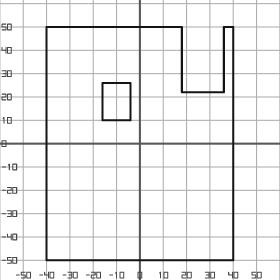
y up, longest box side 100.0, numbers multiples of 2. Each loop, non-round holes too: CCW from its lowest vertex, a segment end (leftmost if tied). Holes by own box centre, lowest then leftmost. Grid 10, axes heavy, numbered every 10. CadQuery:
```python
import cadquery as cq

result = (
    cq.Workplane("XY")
    .moveTo(-40.0, -50.0)
    .lineTo(40.0, -50.0)
    .lineTo(40.0, 50.0)
    .lineTo(36.0, 50.0)
    .lineTo(36.0, 22.0)
    .lineTo(18.0, 22.0)
    .lineTo(18.0, 50.0)
    .lineTo(-40.0, 50.0)
    .close()
    .moveTo(-16.0, 10.0)
    .lineTo(-4.0, 10.0)
    .lineTo(-4.0, 26.0)
    .lineTo(-16.0, 26.0)
    .close()
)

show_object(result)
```